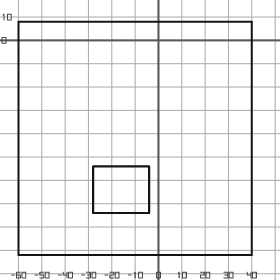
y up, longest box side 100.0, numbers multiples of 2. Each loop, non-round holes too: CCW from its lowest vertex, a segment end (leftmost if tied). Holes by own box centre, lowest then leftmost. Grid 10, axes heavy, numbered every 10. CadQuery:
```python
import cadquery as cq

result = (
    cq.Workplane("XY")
    .moveTo(-60.0, -92.0)
    .lineTo(40.0, -92.0)
    .lineTo(40.0, 8.0)
    .lineTo(-60.0, 8.0)
    .close()
    .moveTo(-28.0, -74.0)
    .lineTo(-4.0, -74.0)
    .lineTo(-4.0, -54.0)
    .lineTo(-28.0, -54.0)
    .close()
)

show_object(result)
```